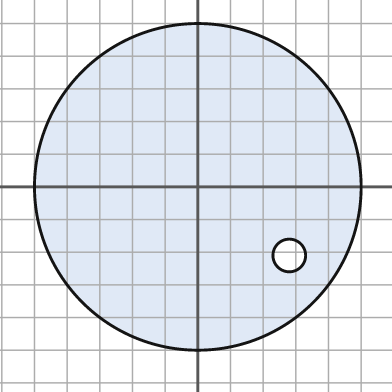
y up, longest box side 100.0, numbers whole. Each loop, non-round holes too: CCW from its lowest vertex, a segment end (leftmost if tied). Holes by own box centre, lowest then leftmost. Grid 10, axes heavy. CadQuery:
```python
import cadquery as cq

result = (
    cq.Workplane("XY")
    .moveTo(0.0, 0.0)
    .circle(50.0)
    .moveTo(28.0, -21.0)
    .circle(5.0)
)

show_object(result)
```